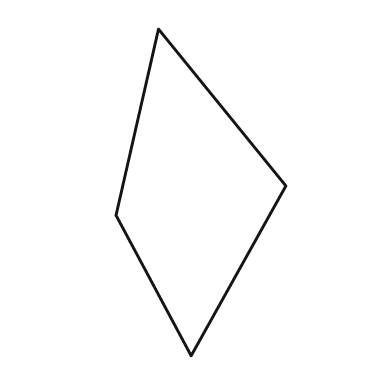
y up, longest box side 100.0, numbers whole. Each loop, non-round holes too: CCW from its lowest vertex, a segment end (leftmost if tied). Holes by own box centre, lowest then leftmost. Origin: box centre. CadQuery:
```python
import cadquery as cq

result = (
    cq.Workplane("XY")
    .moveTo(-3.0, -50.0)
    .lineTo(26.0, 2.0)
    .lineTo(-13.0, 50.0)
    .lineTo(-26.0, -7.0)
    .close()
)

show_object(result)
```